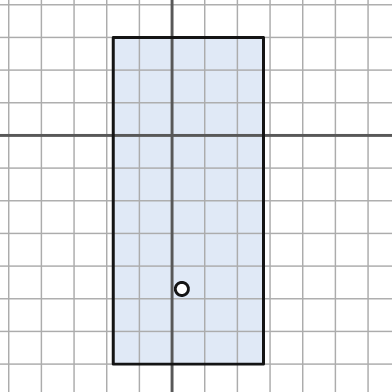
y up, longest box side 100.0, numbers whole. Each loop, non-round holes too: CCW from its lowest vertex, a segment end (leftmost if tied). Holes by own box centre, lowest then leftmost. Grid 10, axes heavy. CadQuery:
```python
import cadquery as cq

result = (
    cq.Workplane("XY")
    .moveTo(-18.0, -70.0)
    .lineTo(28.0, -70.0)
    .lineTo(28.0, 30.0)
    .lineTo(-18.0, 30.0)
    .close()
    .moveTo(3.0, -47.0)
    .circle(2.0)
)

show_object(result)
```